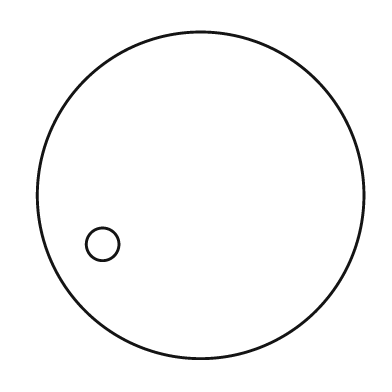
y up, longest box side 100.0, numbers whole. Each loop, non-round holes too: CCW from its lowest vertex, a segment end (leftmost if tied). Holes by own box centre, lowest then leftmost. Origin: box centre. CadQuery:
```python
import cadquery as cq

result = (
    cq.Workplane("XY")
    .moveTo(0.0, 0.0)
    .circle(50.0)
    .moveTo(-30.0, -15.0)
    .circle(5.0)
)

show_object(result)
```